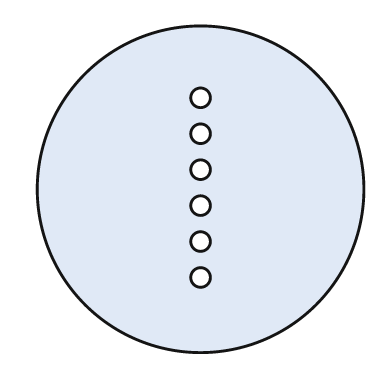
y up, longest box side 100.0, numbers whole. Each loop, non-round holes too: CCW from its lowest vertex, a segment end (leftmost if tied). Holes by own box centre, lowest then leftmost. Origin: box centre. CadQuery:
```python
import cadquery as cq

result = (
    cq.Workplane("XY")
    .moveTo(0.0, 0.0)
    .circle(50.0)
    .moveTo(0.0, -27.0)
    .circle(3.0)
    .moveTo(0.0, -16.0)
    .circle(3.0)
    .moveTo(0.0, -5.0)
    .circle(3.0)
    .moveTo(0.0, 6.0)
    .circle(3.0)
    .moveTo(0.0, 17.0)
    .circle(3.0)
    .moveTo(0.0, 28.0)
    .circle(3.0)
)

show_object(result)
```